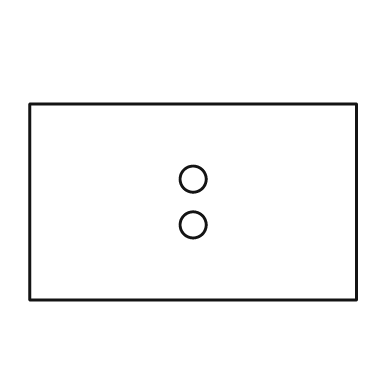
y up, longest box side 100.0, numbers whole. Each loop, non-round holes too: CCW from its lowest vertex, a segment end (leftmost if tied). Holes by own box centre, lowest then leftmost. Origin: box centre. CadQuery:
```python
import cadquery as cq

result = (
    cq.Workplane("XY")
    .moveTo(-50.0, -30.0)
    .lineTo(50.0, -30.0)
    .lineTo(50.0, 30.0)
    .lineTo(-50.0, 30.0)
    .close()
    .moveTo(0.0, -7.0)
    .circle(4.0)
    .moveTo(0.0, 7.0)
    .circle(4.0)
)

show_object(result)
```